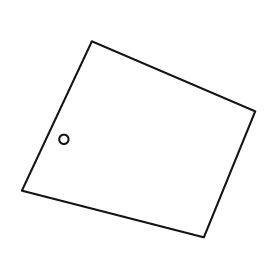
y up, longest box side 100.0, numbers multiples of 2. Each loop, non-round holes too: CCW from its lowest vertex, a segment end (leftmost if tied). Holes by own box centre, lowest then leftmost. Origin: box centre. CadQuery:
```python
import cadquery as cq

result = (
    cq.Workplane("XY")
    .moveTo(28.0, -42.0)
    .lineTo(50.0, 12.0)
    .lineTo(-20.0, 42.0)
    .lineTo(-50.0, -22.0)
    .close()
    .moveTo(-32.0, 0.0)
    .circle(2.0)
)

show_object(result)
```